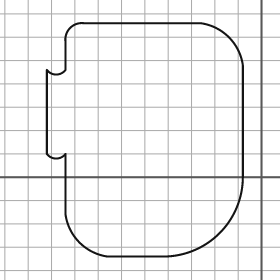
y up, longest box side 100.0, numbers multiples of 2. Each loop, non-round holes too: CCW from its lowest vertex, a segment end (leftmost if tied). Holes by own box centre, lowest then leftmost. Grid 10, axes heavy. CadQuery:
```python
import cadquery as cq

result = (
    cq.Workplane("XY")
    .moveTo(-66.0, -34.0)
    .lineTo(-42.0, -34.0)
    .threePointArc((-18.0, -24.0), (-8.0, 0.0))
    .lineTo(-8.0, 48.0)
    .threePointArc((-14.0, 60.0), (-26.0, 66.0))
    .lineTo(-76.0, 66.0)
    .threePointArc((-82.0, 64.0), (-84.0, 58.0))
    .lineTo(-84.0, 46.0)
    .threePointArc((-88.0, 44.0), (-92.0, 46.0))
    .lineTo(-92.0, 10.0)
    .threePointArc((-88.0, 8.0), (-84.0, 10.0))
    .lineTo(-84.0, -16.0)
    .threePointArc((-78.0, -28.0), (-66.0, -34.0))
    .close()
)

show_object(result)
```